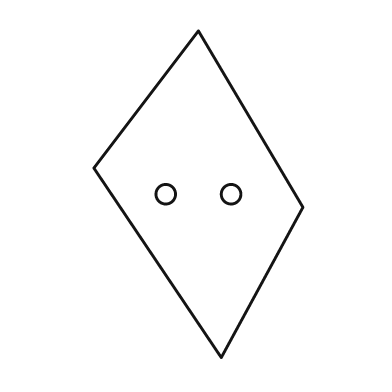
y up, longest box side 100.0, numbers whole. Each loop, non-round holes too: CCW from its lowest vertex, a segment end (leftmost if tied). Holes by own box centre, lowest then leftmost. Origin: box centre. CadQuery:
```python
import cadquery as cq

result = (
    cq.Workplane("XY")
    .moveTo(7.0, -50.0)
    .lineTo(32.0, -4.0)
    .lineTo(0.0, 50.0)
    .lineTo(-32.0, 8.0)
    .close()
    .moveTo(-10.0, 0.0)
    .circle(3.0)
    .moveTo(10.0, 0.0)
    .circle(3.0)
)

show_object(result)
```